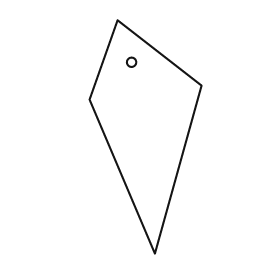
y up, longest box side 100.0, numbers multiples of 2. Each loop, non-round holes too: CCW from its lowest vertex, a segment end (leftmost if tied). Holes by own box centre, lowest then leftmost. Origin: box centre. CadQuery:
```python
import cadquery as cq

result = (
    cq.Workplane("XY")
    .moveTo(4.0, -50.0)
    .lineTo(24.0, 22.0)
    .lineTo(-12.0, 50.0)
    .lineTo(-24.0, 16.0)
    .close()
    .moveTo(-6.0, 32.0)
    .circle(2.0)
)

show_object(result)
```